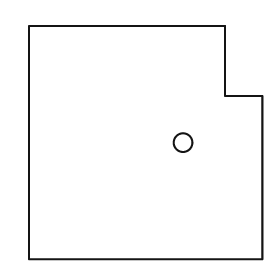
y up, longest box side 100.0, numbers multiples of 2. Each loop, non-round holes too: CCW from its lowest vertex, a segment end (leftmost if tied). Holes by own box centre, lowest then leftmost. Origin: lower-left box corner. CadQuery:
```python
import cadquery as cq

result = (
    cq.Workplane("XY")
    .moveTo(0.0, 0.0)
    .lineTo(100.0, 0.0)
    .lineTo(100.0, 70.0)
    .lineTo(84.0, 70.0)
    .lineTo(84.0, 100.0)
    .lineTo(0.0, 100.0)
    .close()
    .moveTo(66.0, 50.0)
    .circle(4.0)
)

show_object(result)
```